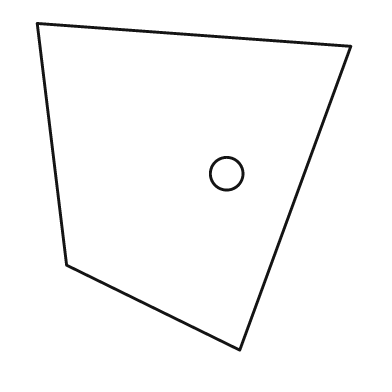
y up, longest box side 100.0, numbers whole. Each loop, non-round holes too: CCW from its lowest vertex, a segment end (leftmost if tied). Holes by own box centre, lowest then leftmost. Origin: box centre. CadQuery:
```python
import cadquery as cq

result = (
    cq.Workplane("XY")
    .moveTo(14.0, -50.0)
    .lineTo(48.0, 43.0)
    .lineTo(-48.0, 50.0)
    .lineTo(-39.0, -24.0)
    .close()
    .moveTo(10.0, 4.0)
    .circle(5.0)
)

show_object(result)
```